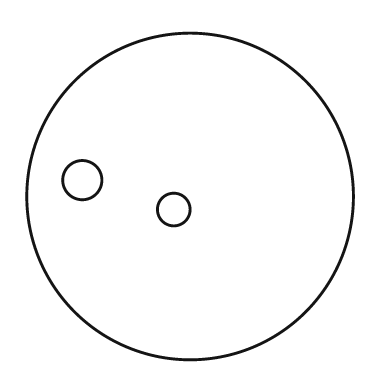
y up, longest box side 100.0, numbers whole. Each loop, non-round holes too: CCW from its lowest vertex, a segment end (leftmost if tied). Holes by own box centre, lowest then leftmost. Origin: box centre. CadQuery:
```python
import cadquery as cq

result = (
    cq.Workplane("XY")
    .moveTo(0.0, 0.0)
    .circle(50.0)
    .moveTo(-5.0, -4.0)
    .circle(5.0)
    .moveTo(-33.0, 5.0)
    .circle(6.0)
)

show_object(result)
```